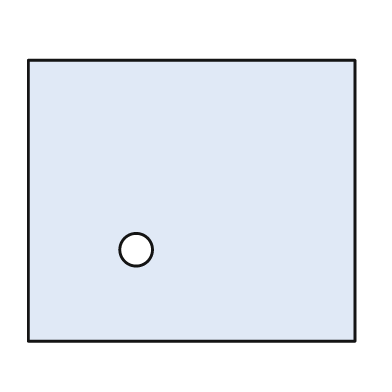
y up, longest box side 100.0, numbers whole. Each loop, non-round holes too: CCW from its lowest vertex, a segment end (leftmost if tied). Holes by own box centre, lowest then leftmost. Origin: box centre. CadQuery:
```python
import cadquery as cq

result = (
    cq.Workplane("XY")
    .moveTo(-50.0, -43.0)
    .lineTo(50.0, -43.0)
    .lineTo(50.0, 43.0)
    .lineTo(-50.0, 43.0)
    .close()
    .moveTo(-17.0, -15.0)
    .circle(5.0)
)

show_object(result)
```